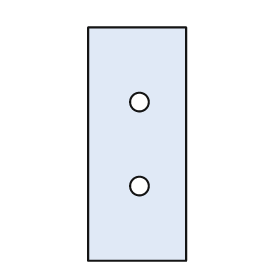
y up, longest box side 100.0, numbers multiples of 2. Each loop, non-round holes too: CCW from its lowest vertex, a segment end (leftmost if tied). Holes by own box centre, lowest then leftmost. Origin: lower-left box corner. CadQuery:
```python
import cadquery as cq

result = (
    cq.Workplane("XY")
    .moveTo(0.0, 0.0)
    .lineTo(42.0, 0.0)
    .lineTo(42.0, 100.0)
    .lineTo(0.0, 100.0)
    .close()
    .moveTo(22.0, 32.0)
    .circle(4.0)
    .moveTo(22.0, 68.0)
    .circle(4.0)
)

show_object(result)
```